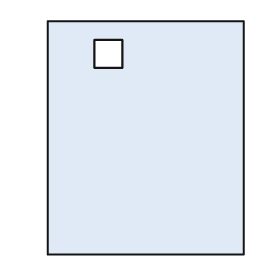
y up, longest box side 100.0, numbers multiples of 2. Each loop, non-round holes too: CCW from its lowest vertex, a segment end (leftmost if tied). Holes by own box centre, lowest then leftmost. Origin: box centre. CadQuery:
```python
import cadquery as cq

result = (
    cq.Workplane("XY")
    .moveTo(-42.0, -50.0)
    .lineTo(42.0, -50.0)
    .lineTo(42.0, 50.0)
    .lineTo(-42.0, 50.0)
    .close()
    .moveTo(-22.0, 30.0)
    .lineTo(-10.0, 30.0)
    .lineTo(-10.0, 42.0)
    .lineTo(-22.0, 42.0)
    .close()
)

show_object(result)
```